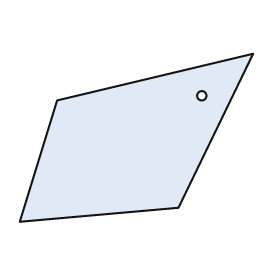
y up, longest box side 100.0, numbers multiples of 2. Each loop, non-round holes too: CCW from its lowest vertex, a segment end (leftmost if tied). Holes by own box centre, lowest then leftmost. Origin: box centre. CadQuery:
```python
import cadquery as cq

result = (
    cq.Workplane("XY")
    .moveTo(-50.0, -36.0)
    .lineTo(18.0, -30.0)
    .lineTo(50.0, 36.0)
    .lineTo(-34.0, 16.0)
    .close()
    .moveTo(28.0, 18.0)
    .circle(2.0)
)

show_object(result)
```